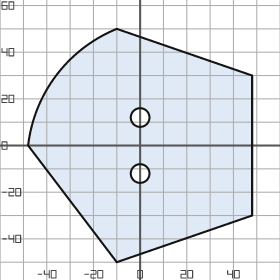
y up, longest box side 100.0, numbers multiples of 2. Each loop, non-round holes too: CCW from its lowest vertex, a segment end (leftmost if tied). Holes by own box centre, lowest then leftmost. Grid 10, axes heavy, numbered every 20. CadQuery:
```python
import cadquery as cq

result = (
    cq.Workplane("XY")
    .moveTo(-10.0, -50.0)
    .lineTo(48.0, -30.0)
    .lineTo(48.0, 30.0)
    .lineTo(-10.0, 50.0)
    .threePointArc((-36.0, 30.0), (-48.0, 0.0))
    .close()
    .moveTo(0.0, -12.0)
    .circle(4.0)
    .moveTo(0.0, 12.0)
    .circle(4.0)
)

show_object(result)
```